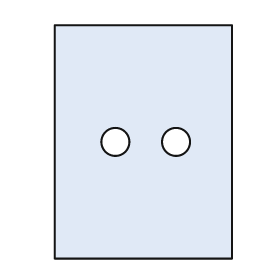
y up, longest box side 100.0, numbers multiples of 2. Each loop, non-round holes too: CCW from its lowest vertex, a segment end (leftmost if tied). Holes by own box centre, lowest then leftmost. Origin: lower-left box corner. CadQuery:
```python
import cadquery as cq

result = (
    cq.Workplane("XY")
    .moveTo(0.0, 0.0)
    .lineTo(76.0, 0.0)
    .lineTo(76.0, 100.0)
    .lineTo(0.0, 100.0)
    .close()
    .moveTo(26.0, 50.0)
    .circle(6.0)
    .moveTo(52.0, 50.0)
    .circle(6.0)
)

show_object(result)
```